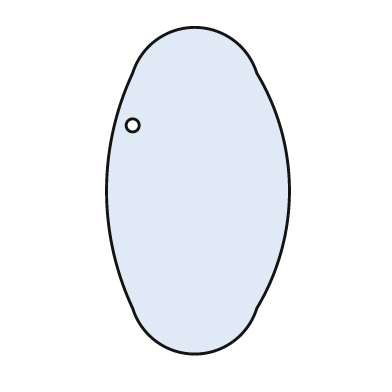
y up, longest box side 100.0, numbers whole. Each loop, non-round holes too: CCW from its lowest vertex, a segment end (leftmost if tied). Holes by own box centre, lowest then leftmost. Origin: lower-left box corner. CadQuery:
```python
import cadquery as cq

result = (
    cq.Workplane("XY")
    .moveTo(8.0, 14.0)
    .threePointArc((27.0, 0.0), (46.0, 14.0))
    .threePointArc((56.0, 50.0), (46.0, 86.0))
    .threePointArc((27.0, 100.0), (8.0, 86.0))
    .threePointArc((0.0, 50.0), (8.0, 14.0))
    .close()
    .moveTo(8.0, 70.0)
    .circle(2.0)
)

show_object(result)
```